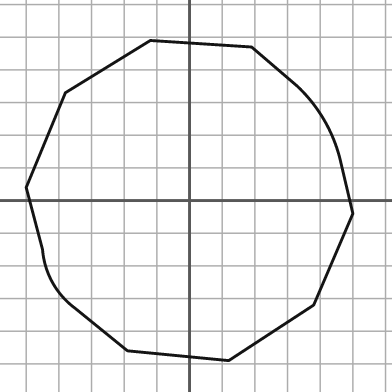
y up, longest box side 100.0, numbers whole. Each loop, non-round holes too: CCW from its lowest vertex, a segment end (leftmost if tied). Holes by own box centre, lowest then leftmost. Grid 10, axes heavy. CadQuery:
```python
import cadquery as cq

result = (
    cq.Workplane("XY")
    .moveTo(12.0, -49.0)
    .lineTo(38.0, -32.0)
    .lineTo(50.0, -4.0)
    .lineTo(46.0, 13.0)
    .threePointArc((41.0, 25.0), (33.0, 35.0))
    .lineTo(19.0, 47.0)
    .lineTo(-12.0, 49.0)
    .lineTo(-38.0, 33.0)
    .lineTo(-50.0, 4.0)
    .lineTo(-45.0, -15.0)
    .threePointArc((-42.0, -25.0), (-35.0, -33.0))
    .lineTo(-19.0, -46.0)
    .close()
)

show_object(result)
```